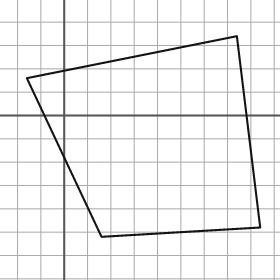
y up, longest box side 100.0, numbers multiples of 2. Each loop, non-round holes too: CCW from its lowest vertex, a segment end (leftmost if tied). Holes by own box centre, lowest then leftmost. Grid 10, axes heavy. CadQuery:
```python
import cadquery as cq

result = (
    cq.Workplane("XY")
    .moveTo(16.0, -52.0)
    .lineTo(84.0, -48.0)
    .lineTo(74.0, 34.0)
    .lineTo(-16.0, 16.0)
    .close()
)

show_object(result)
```